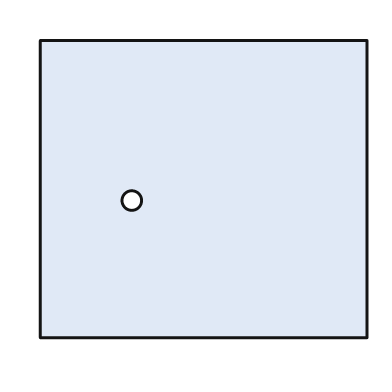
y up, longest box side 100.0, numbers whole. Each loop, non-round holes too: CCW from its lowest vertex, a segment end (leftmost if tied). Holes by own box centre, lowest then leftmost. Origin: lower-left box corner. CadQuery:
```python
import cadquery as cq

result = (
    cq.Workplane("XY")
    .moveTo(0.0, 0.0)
    .lineTo(100.0, 0.0)
    .lineTo(100.0, 91.0)
    .lineTo(0.0, 91.0)
    .close()
    .moveTo(28.0, 42.0)
    .circle(3.0)
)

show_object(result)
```